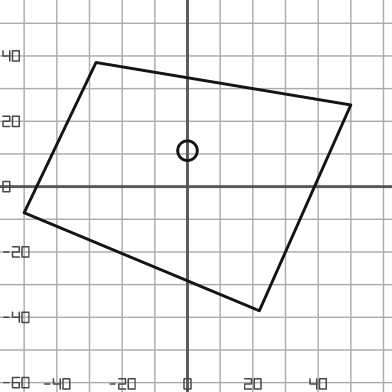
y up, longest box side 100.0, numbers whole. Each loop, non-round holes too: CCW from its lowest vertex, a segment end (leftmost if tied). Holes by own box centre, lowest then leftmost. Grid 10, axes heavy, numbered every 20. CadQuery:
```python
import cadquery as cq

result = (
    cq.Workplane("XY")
    .moveTo(22.0, -38.0)
    .lineTo(50.0, 25.0)
    .lineTo(-28.0, 38.0)
    .lineTo(-50.0, -8.0)
    .close()
    .moveTo(0.0, 11.0)
    .circle(3.0)
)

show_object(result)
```